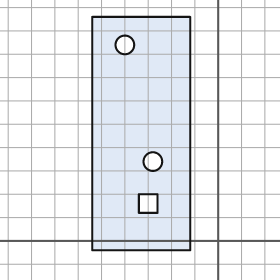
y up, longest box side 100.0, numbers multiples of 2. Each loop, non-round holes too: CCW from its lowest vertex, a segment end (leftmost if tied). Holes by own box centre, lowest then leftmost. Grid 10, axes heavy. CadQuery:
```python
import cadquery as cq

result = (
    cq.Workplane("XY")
    .moveTo(-54.0, -4.0)
    .lineTo(-12.0, -4.0)
    .lineTo(-12.0, 96.0)
    .lineTo(-54.0, 96.0)
    .close()
    .moveTo(-34.0, 12.0)
    .lineTo(-26.0, 12.0)
    .lineTo(-26.0, 20.0)
    .lineTo(-34.0, 20.0)
    .close()
    .moveTo(-28.0, 34.0)
    .circle(4.0)
    .moveTo(-40.0, 84.0)
    .circle(4.0)
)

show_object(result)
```